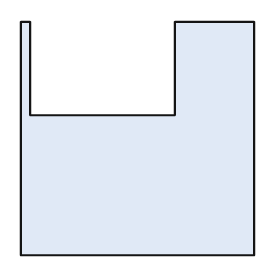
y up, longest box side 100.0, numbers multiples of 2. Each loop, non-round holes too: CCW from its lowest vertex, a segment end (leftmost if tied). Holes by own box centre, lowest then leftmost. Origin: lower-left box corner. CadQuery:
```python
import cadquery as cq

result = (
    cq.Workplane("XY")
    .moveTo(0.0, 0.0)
    .lineTo(100.0, 0.0)
    .lineTo(100.0, 100.0)
    .lineTo(66.0, 100.0)
    .lineTo(66.0, 60.0)
    .lineTo(4.0, 60.0)
    .lineTo(4.0, 100.0)
    .lineTo(0.0, 100.0)
    .close()
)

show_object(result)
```